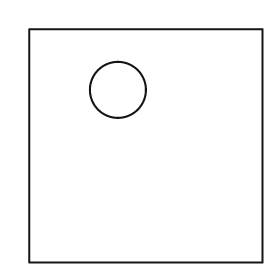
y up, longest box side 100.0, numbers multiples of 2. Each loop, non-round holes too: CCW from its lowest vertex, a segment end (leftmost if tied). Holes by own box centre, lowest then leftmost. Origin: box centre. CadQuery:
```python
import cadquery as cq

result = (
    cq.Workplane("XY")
    .moveTo(-50.0, -50.0)
    .lineTo(50.0, -50.0)
    .lineTo(50.0, 50.0)
    .lineTo(-50.0, 50.0)
    .close()
    .moveTo(-12.0, 24.0)
    .circle(12.0)
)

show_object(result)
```